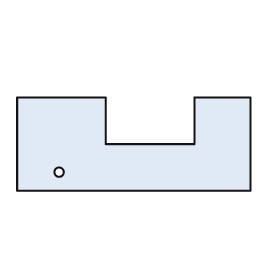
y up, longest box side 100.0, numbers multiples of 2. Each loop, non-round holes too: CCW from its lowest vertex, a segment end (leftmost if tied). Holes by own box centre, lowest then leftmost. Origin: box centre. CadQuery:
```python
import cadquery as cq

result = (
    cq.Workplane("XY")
    .moveTo(-50.0, -20.0)
    .lineTo(50.0, -20.0)
    .lineTo(50.0, 20.0)
    .lineTo(26.0, 20.0)
    .lineTo(26.0, 0.0)
    .lineTo(-12.0, 0.0)
    .lineTo(-12.0, 20.0)
    .lineTo(-50.0, 20.0)
    .close()
    .moveTo(-32.0, -12.0)
    .circle(2.0)
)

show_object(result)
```